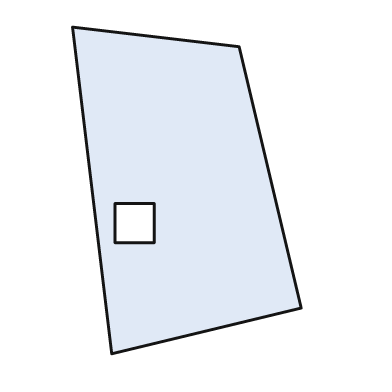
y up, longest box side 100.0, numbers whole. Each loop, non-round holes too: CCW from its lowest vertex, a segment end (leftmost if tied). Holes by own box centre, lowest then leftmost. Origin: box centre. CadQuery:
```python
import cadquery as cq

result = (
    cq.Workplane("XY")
    .moveTo(-23.0, -50.0)
    .lineTo(35.0, -36.0)
    .lineTo(16.0, 44.0)
    .lineTo(-35.0, 50.0)
    .close()
    .moveTo(-22.0, -16.0)
    .lineTo(-10.0, -16.0)
    .lineTo(-10.0, -4.0)
    .lineTo(-22.0, -4.0)
    .close()
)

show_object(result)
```